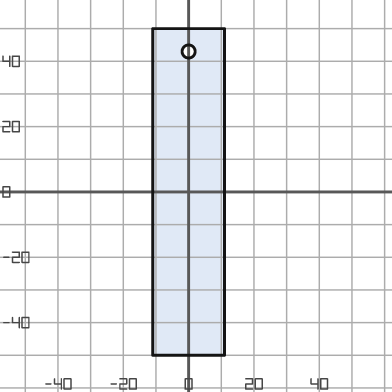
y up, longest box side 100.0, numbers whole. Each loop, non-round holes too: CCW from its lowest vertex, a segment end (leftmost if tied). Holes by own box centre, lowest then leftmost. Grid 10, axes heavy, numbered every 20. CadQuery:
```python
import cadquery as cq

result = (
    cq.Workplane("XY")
    .moveTo(-11.0, -50.0)
    .lineTo(11.0, -50.0)
    .lineTo(11.0, 50.0)
    .lineTo(-11.0, 50.0)
    .close()
    .moveTo(0.0, 43.0)
    .circle(2.0)
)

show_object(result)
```